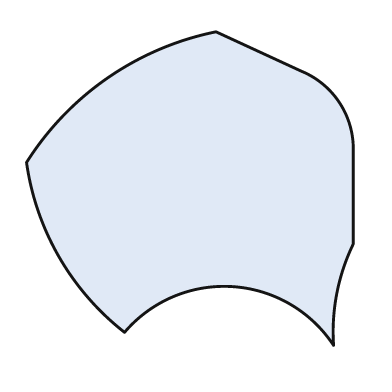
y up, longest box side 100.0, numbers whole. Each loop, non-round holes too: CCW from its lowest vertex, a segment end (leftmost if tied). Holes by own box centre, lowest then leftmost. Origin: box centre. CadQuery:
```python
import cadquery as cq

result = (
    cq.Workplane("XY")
    .moveTo(44.0, -48.0)
    .threePointArc((45.0, -32.0), (50.0, -17.0))
    .lineTo(50.0, 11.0)
    .threePointArc((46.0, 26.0), (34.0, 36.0))
    .lineTo(8.0, 48.0)
    .threePointArc((-25.0, 34.0), (-50.0, 8.0))
    .threePointArc((-40.0, -21.0), (-20.0, -44.0))
    .threePointArc((13.0, -30.0), (44.0, -48.0))
    .close()
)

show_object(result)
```